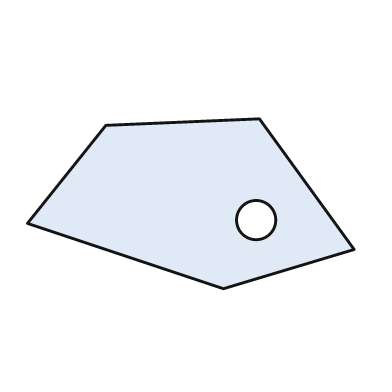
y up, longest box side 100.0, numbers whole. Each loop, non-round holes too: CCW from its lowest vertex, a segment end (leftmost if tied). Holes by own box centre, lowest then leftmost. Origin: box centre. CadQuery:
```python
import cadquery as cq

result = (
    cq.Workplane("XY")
    .moveTo(10.0, -26.0)
    .lineTo(50.0, -14.0)
    .lineTo(21.0, 26.0)
    .lineTo(-26.0, 24.0)
    .lineTo(-50.0, -6.0)
    .close()
    .moveTo(20.0, -5.0)
    .circle(6.0)
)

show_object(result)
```